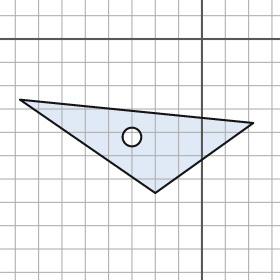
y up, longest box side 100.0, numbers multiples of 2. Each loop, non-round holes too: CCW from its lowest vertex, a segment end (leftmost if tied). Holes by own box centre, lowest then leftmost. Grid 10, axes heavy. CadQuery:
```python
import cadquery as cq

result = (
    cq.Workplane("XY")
    .moveTo(-20.0, -66.0)
    .lineTo(22.0, -36.0)
    .lineTo(-78.0, -26.0)
    .close()
    .moveTo(-30.0, -42.0)
    .circle(4.0)
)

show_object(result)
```